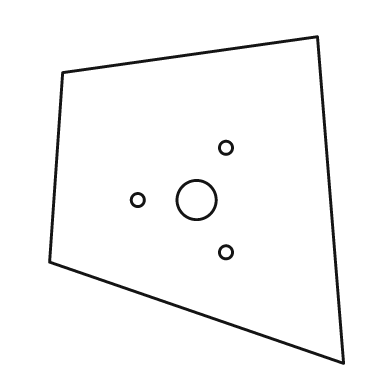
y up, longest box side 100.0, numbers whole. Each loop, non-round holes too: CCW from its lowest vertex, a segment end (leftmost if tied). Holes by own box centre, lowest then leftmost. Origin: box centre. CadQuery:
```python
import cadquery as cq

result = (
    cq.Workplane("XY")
    .moveTo(45.0, -50.0)
    .lineTo(37.0, 50.0)
    .lineTo(-41.0, 39.0)
    .lineTo(-45.0, -19.0)
    .close()
    .moveTo(9.0, -16.0)
    .circle(2.0)
    .moveTo(-18.0, 0.0)
    .circle(2.0)
    .moveTo(0.0, 0.0)
    .circle(6.0)
    .moveTo(9.0, 16.0)
    .circle(2.0)
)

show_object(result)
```